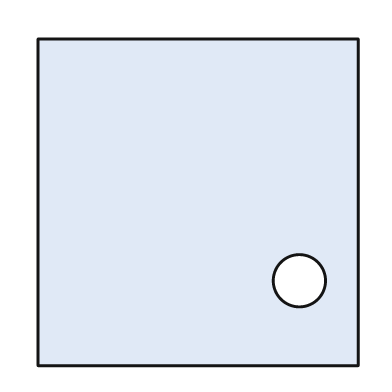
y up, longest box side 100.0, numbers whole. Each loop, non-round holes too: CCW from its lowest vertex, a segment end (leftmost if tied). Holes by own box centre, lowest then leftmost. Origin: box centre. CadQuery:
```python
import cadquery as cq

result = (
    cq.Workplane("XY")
    .moveTo(-49.0, -50.0)
    .lineTo(49.0, -50.0)
    .lineTo(49.0, 50.0)
    .lineTo(-49.0, 50.0)
    .close()
    .moveTo(31.0, -24.0)
    .circle(8.0)
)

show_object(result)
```